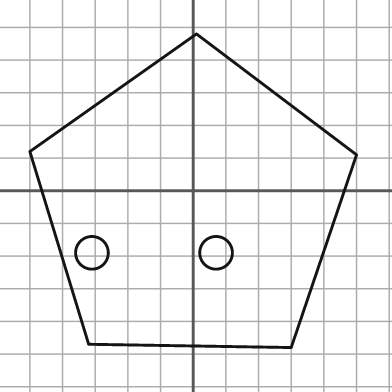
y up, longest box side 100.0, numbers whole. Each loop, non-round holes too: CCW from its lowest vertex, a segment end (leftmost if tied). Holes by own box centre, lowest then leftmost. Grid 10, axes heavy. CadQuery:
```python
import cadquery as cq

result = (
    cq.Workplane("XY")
    .moveTo(30.0, -48.0)
    .lineTo(50.0, 11.0)
    .lineTo(1.0, 48.0)
    .lineTo(-50.0, 12.0)
    .lineTo(-32.0, -47.0)
    .close()
    .moveTo(-31.0, -19.0)
    .circle(5.0)
    .moveTo(7.0, -19.0)
    .circle(5.0)
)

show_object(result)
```